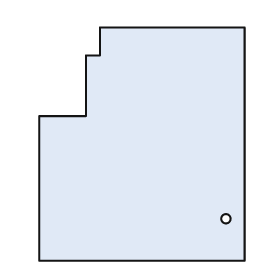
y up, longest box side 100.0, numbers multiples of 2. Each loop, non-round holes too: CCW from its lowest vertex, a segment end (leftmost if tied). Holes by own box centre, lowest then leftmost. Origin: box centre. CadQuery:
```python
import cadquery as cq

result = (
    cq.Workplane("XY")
    .moveTo(-44.0, -50.0)
    .lineTo(44.0, -50.0)
    .lineTo(44.0, 50.0)
    .lineTo(-18.0, 50.0)
    .lineTo(-18.0, 38.0)
    .lineTo(-24.0, 38.0)
    .lineTo(-24.0, 12.0)
    .lineTo(-44.0, 12.0)
    .close()
    .moveTo(36.0, -32.0)
    .circle(2.0)
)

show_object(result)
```